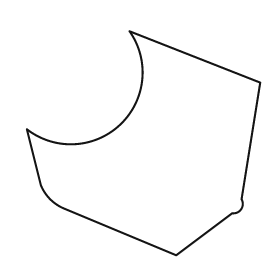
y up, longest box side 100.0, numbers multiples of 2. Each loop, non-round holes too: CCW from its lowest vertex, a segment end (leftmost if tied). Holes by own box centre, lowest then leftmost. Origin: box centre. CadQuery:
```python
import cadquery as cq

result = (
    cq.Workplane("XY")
    .moveTo(14.0, -48.0)
    .lineTo(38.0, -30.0)
    .threePointArc((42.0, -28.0), (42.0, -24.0))
    .lineTo(50.0, 26.0)
    .lineTo(-6.0, 48.0)
    .threePointArc((-10.0, 8.0), (-50.0, 6.0))
    .lineTo(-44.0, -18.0)
    .threePointArc((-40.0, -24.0), (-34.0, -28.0))
    .close()
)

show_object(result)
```